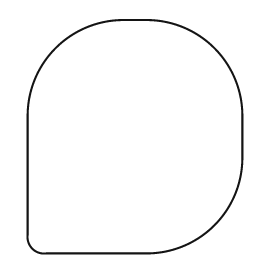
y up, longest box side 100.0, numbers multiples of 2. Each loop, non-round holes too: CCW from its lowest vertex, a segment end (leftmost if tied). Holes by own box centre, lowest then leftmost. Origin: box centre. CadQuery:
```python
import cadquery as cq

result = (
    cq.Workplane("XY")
    .moveTo(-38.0, -50.0)
    .lineTo(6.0, -50.0)
    .threePointArc((34.0, -38.0), (46.0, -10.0))
    .lineTo(46.0, 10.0)
    .threePointArc((34.0, 38.0), (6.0, 50.0))
    .lineTo(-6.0, 50.0)
    .threePointArc((-34.0, 38.0), (-46.0, 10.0))
    .lineTo(-46.0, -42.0)
    .threePointArc((-44.0, -48.0), (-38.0, -50.0))
    .close()
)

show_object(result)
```